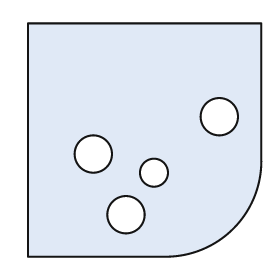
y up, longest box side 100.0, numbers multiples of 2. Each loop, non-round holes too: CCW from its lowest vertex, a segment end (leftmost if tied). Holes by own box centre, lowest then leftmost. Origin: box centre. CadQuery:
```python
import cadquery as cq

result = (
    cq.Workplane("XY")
    .moveTo(-50.0, -50.0)
    .lineTo(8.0, -50.0)
    .threePointArc((38.0, -38.0), (50.0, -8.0))
    .lineTo(50.0, 50.0)
    .lineTo(-50.0, 50.0)
    .close()
    .moveTo(-8.0, -32.0)
    .circle(8.0)
    .moveTo(4.0, -14.0)
    .circle(6.0)
    .moveTo(-22.0, -6.0)
    .circle(8.0)
    .moveTo(32.0, 10.0)
    .circle(8.0)
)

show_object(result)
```